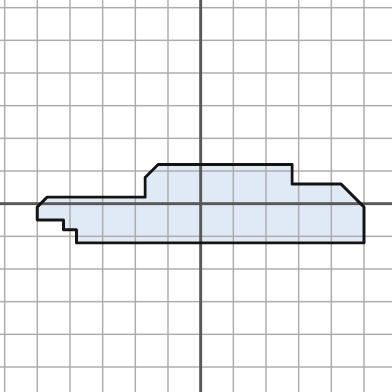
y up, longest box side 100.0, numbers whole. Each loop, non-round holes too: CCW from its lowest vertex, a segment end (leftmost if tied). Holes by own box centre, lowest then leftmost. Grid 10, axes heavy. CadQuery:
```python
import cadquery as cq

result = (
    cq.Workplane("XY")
    .moveTo(-38.0, -12.0)
    .lineTo(50.0, -12.0)
    .lineTo(50.0, -1.0)
    .lineTo(43.0, 6.0)
    .lineTo(28.0, 6.0)
    .lineTo(28.0, 12.0)
    .lineTo(-13.0, 12.0)
    .lineTo(-17.0, 8.0)
    .lineTo(-17.0, 2.0)
    .lineTo(-47.0, 2.0)
    .lineTo(-50.0, -1.0)
    .lineTo(-50.0, -5.0)
    .lineTo(-42.0, -5.0)
    .lineTo(-42.0, -8.0)
    .lineTo(-38.0, -8.0)
    .close()
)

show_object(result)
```